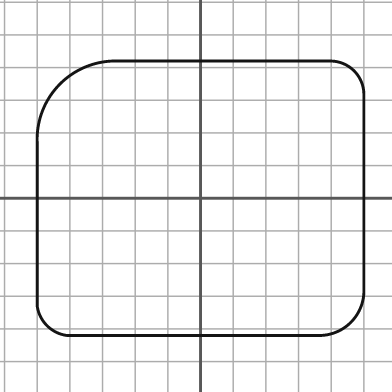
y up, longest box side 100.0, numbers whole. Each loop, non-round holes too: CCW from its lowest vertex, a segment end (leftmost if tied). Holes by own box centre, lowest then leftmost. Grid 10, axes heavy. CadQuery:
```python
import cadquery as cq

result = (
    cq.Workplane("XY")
    .moveTo(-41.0, -42.0)
    .lineTo(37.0, -42.0)
    .threePointArc((46.0, -38.0), (50.0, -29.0))
    .lineTo(50.0, 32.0)
    .threePointArc((47.0, 39.0), (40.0, 42.0))
    .lineTo(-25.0, 42.0)
    .threePointArc((-43.0, 35.0), (-50.0, 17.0))
    .lineTo(-50.0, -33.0)
    .threePointArc((-47.0, -39.0), (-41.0, -42.0))
    .close()
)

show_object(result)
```